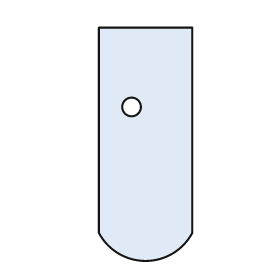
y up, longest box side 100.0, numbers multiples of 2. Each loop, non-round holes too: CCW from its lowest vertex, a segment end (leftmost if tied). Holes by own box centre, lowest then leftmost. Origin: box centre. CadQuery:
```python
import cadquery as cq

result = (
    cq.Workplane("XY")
    .moveTo(-20.0, -38.0)
    .threePointArc((0.0, -50.0), (20.0, -38.0))
    .lineTo(20.0, 50.0)
    .lineTo(-20.0, 50.0)
    .close()
    .moveTo(-6.0, 16.0)
    .circle(4.0)
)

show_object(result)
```